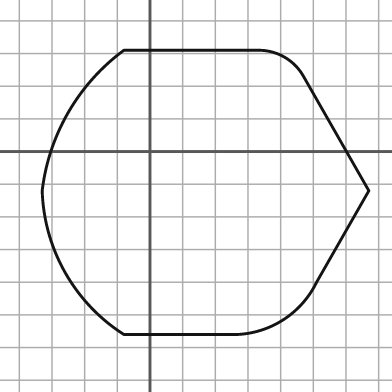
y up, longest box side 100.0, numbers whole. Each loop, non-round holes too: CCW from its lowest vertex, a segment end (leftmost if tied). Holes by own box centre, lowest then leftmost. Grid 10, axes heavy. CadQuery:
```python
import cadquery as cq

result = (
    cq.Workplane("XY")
    .moveTo(-8.0, -56.0)
    .lineTo(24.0, -56.0)
    .threePointArc((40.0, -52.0), (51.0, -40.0))
    .lineTo(67.0, -12.0)
    .lineTo(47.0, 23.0)
    .threePointArc((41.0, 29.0), (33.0, 31.0))
    .lineTo(-8.0, 31.0)
    .threePointArc((-25.0, 12.0), (-33.0, -12.0))
    .threePointArc((-26.0, -37.0), (-8.0, -56.0))
    .close()
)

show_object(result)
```